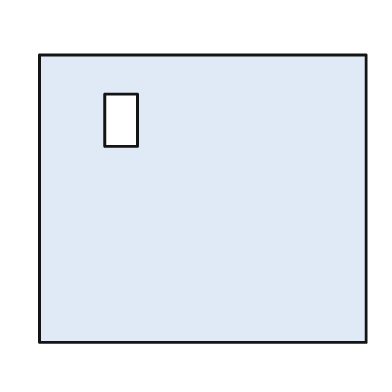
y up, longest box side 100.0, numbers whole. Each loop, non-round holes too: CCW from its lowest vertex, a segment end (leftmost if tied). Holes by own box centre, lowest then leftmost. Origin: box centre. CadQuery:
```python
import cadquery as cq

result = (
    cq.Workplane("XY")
    .moveTo(-50.0, -44.0)
    .lineTo(50.0, -44.0)
    .lineTo(50.0, 44.0)
    .lineTo(-50.0, 44.0)
    .close()
    .moveTo(-30.0, 16.0)
    .lineTo(-20.0, 16.0)
    .lineTo(-20.0, 32.0)
    .lineTo(-30.0, 32.0)
    .close()
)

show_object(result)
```